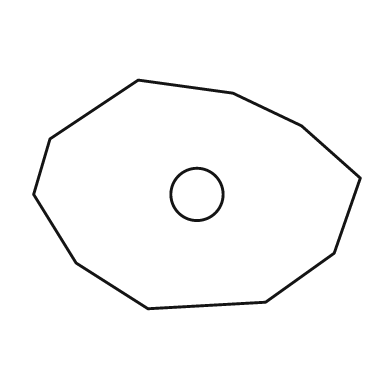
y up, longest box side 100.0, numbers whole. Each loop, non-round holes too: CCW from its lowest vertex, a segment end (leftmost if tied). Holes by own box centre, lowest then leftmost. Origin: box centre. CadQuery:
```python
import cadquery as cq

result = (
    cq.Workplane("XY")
    .moveTo(-15.0, -35.0)
    .lineTo(21.0, -33.0)
    .lineTo(42.0, -18.0)
    .lineTo(50.0, 5.0)
    .lineTo(32.0, 21.0)
    .lineTo(11.0, 31.0)
    .lineTo(-18.0, 35.0)
    .lineTo(-45.0, 17.0)
    .lineTo(-50.0, 0.0)
    .lineTo(-37.0, -21.0)
    .close()
    .moveTo(0.0, 0.0)
    .circle(8.0)
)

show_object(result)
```